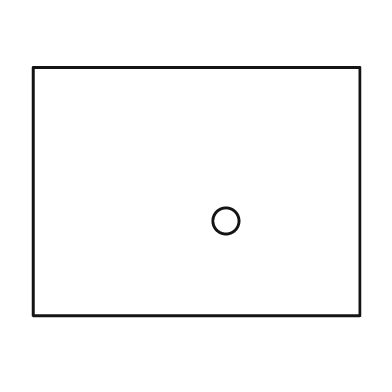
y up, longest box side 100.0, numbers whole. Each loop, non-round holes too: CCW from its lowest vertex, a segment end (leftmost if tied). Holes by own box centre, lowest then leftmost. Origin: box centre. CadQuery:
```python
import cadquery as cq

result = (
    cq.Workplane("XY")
    .moveTo(-50.0, -38.0)
    .lineTo(50.0, -38.0)
    .lineTo(50.0, 38.0)
    .lineTo(-50.0, 38.0)
    .close()
    .moveTo(9.0, -9.0)
    .circle(4.0)
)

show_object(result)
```